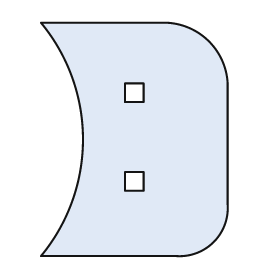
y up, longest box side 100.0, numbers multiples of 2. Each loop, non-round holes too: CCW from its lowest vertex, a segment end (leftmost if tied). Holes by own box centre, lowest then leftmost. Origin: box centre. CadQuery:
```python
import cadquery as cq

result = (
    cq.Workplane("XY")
    .moveTo(-40.0, -50.0)
    .lineTo(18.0, -50.0)
    .threePointArc((34.0, -44.0), (40.0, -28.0))
    .lineTo(40.0, 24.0)
    .threePointArc((32.0, 42.0), (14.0, 50.0))
    .lineTo(-40.0, 50.0)
    .threePointArc((-22.0, 0.0), (-40.0, -50.0))
    .close()
    .moveTo(-4.0, -22.0)
    .lineTo(4.0, -22.0)
    .lineTo(4.0, -14.0)
    .lineTo(-4.0, -14.0)
    .close()
    .moveTo(-4.0, 16.0)
    .lineTo(4.0, 16.0)
    .lineTo(4.0, 24.0)
    .lineTo(-4.0, 24.0)
    .close()
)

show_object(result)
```